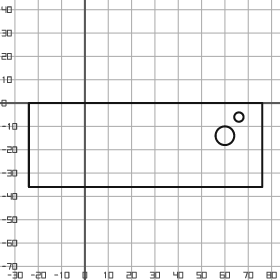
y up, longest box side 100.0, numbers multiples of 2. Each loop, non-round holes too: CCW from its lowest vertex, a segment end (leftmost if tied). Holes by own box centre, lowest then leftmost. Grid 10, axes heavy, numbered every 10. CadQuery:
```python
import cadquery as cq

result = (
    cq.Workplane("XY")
    .moveTo(-24.0, -36.0)
    .lineTo(76.0, -36.0)
    .lineTo(76.0, 0.0)
    .lineTo(-24.0, 0.0)
    .close()
    .moveTo(60.0, -14.0)
    .circle(4.0)
    .moveTo(66.0, -6.0)
    .circle(2.0)
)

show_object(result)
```